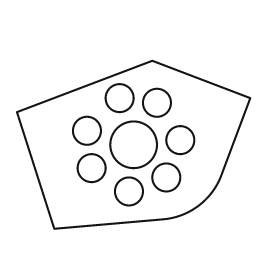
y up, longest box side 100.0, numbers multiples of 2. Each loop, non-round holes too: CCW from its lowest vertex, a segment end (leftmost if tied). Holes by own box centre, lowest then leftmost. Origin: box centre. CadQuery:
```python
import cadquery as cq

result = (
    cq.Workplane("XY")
    .moveTo(-34.0, -36.0)
    .lineTo(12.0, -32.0)
    .threePointArc((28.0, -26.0), (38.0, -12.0))
    .lineTo(50.0, 20.0)
    .lineTo(8.0, 36.0)
    .lineTo(-50.0, 14.0)
    .close()
    .moveTo(-2.0, -20.0)
    .circle(6.0)
    .moveTo(14.0, -14.0)
    .circle(6.0)
    .moveTo(-18.0, -10.0)
    .circle(6.0)
    .moveTo(0.0, 0.0)
    .circle(10.0)
    .moveTo(20.0, 2.0)
    .circle(6.0)
    .moveTo(-20.0, 6.0)
    .circle(6.0)
    .moveTo(10.0, 18.0)
    .circle(6.0)
    .moveTo(-6.0, 20.0)
    .circle(6.0)
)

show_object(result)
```